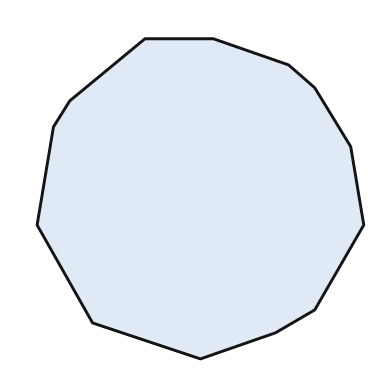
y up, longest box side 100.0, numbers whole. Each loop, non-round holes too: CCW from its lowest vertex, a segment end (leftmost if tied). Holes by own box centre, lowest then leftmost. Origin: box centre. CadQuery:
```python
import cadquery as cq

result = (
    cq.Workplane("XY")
    .moveTo(0.0, -49.0)
    .lineTo(23.0, -41.0)
    .lineTo(35.0, -34.0)
    .lineTo(50.0, -8.0)
    .lineTo(46.0, 16.0)
    .lineTo(35.0, 34.0)
    .lineTo(27.0, 41.0)
    .lineTo(4.0, 49.0)
    .lineTo(-17.0, 49.0)
    .lineTo(-40.0, 30.0)
    .lineTo(-45.0, 22.0)
    .lineTo(-50.0, -8.0)
    .lineTo(-33.0, -38.0)
    .close()
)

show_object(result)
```